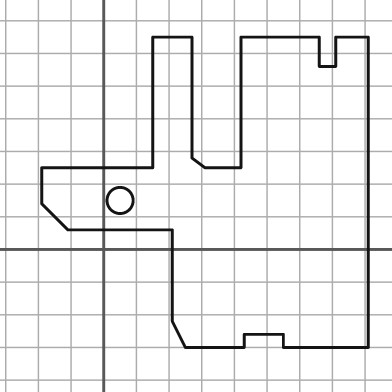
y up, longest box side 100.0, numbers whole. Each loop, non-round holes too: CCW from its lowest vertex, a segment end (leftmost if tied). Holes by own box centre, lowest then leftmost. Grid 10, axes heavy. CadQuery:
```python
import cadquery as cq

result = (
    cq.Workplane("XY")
    .moveTo(25.0, -30.0)
    .lineTo(43.0, -30.0)
    .lineTo(43.0, -26.0)
    .lineTo(55.0, -26.0)
    .lineTo(55.0, -30.0)
    .lineTo(81.0, -30.0)
    .lineTo(81.0, 65.0)
    .lineTo(71.0, 65.0)
    .lineTo(71.0, 56.0)
    .lineTo(66.0, 56.0)
    .lineTo(66.0, 65.0)
    .lineTo(42.0, 65.0)
    .lineTo(42.0, 25.0)
    .lineTo(31.0, 25.0)
    .lineTo(27.0, 28.0)
    .lineTo(27.0, 65.0)
    .lineTo(15.0, 65.0)
    .lineTo(15.0, 25.0)
    .lineTo(-19.0, 25.0)
    .lineTo(-19.0, 14.0)
    .lineTo(-11.0, 6.0)
    .lineTo(21.0, 6.0)
    .lineTo(21.0, -22.0)
    .close()
    .moveTo(5.0, 15.0)
    .circle(4.0)
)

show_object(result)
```